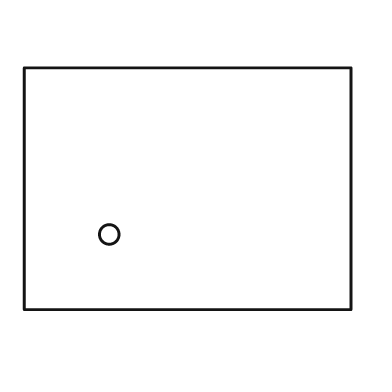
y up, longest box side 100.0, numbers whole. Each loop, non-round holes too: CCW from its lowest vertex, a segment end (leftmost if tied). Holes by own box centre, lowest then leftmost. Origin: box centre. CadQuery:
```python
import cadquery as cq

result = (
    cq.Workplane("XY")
    .moveTo(-50.0, -37.0)
    .lineTo(50.0, -37.0)
    .lineTo(50.0, 37.0)
    .lineTo(-50.0, 37.0)
    .close()
    .moveTo(-24.0, -14.0)
    .circle(3.0)
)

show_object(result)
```